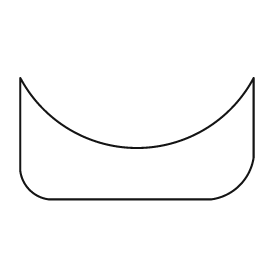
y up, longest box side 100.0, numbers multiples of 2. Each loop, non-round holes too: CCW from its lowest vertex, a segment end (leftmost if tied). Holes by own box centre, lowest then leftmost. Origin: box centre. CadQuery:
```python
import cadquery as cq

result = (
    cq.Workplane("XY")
    .moveTo(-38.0, -26.0)
    .lineTo(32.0, -26.0)
    .threePointArc((44.0, -20.0), (50.0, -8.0))
    .lineTo(50.0, 26.0)
    .threePointArc((0.0, -4.0), (-50.0, 26.0))
    .lineTo(-50.0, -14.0)
    .threePointArc((-46.0, -22.0), (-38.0, -26.0))
    .close()
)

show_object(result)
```